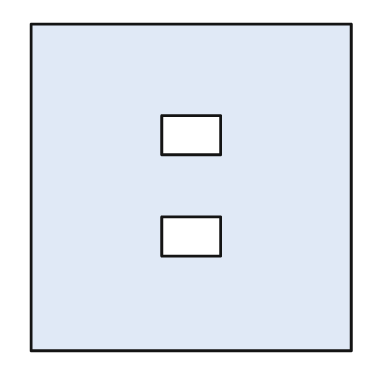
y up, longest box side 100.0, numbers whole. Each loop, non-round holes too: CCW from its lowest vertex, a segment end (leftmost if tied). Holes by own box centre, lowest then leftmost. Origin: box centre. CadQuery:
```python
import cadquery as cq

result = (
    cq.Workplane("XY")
    .moveTo(-49.0, -50.0)
    .lineTo(49.0, -50.0)
    .lineTo(49.0, 50.0)
    .lineTo(-49.0, 50.0)
    .close()
    .moveTo(-9.0, -21.0)
    .lineTo(9.0, -21.0)
    .lineTo(9.0, -9.0)
    .lineTo(-9.0, -9.0)
    .close()
    .moveTo(-9.0, 10.0)
    .lineTo(9.0, 10.0)
    .lineTo(9.0, 22.0)
    .lineTo(-9.0, 22.0)
    .close()
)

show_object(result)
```